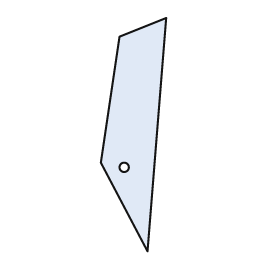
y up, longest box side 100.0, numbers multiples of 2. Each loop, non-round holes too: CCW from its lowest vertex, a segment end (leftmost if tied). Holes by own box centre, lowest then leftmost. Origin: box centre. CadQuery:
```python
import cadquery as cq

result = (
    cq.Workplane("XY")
    .moveTo(6.0, -50.0)
    .lineTo(14.0, 50.0)
    .lineTo(-6.0, 42.0)
    .lineTo(-14.0, -12.0)
    .close()
    .moveTo(-4.0, -14.0)
    .circle(2.0)
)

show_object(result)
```